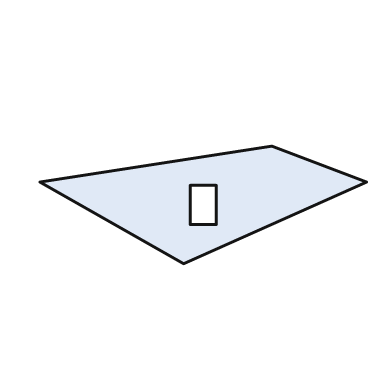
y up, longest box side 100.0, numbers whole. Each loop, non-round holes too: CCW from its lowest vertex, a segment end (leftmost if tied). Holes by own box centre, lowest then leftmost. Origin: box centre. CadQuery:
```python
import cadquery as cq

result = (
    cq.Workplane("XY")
    .moveTo(-6.0, -18.0)
    .lineTo(50.0, 7.0)
    .lineTo(21.0, 18.0)
    .lineTo(-50.0, 7.0)
    .close()
    .moveTo(-4.0, -6.0)
    .lineTo(4.0, -6.0)
    .lineTo(4.0, 6.0)
    .lineTo(-4.0, 6.0)
    .close()
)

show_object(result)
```